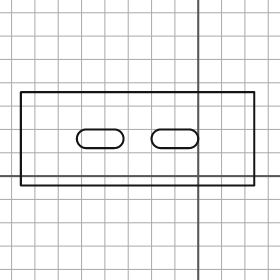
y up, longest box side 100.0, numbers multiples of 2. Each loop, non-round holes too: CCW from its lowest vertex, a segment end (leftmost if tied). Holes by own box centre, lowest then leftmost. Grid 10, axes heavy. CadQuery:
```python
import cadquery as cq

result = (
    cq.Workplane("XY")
    .moveTo(-76.0, -4.0)
    .lineTo(24.0, -4.0)
    .lineTo(24.0, 36.0)
    .lineTo(-76.0, 36.0)
    .close()
    .moveTo(-48.0, 12.0)
    .lineTo(-36.0, 12.0)
    .threePointArc((-32.0, 16.0), (-36.0, 20.0))
    .lineTo(-48.0, 20.0)
    .threePointArc((-52.0, 16.0), (-48.0, 12.0))
    .close()
    .moveTo(-16.0, 12.0)
    .lineTo(-4.0, 12.0)
    .threePointArc((0.0, 16.0), (-4.0, 20.0))
    .lineTo(-16.0, 20.0)
    .threePointArc((-20.0, 16.0), (-16.0, 12.0))
    .close()
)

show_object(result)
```